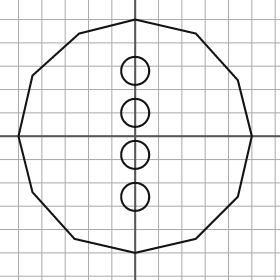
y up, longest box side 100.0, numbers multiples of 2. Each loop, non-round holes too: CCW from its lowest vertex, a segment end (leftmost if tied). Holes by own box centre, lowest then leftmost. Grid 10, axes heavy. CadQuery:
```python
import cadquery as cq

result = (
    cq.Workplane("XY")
    .moveTo(0.0, -50.0)
    .lineTo(26.0, -44.0)
    .lineTo(44.0, -26.0)
    .lineTo(50.0, 0.0)
    .lineTo(44.0, 24.0)
    .lineTo(26.0, 44.0)
    .lineTo(0.0, 50.0)
    .lineTo(-24.0, 44.0)
    .lineTo(-44.0, 26.0)
    .lineTo(-50.0, 0.0)
    .lineTo(-44.0, -24.0)
    .lineTo(-26.0, -44.0)
    .close()
    .moveTo(0.0, -26.0)
    .circle(6.0)
    .moveTo(0.0, -8.0)
    .circle(6.0)
    .moveTo(0.0, 10.0)
    .circle(6.0)
    .moveTo(0.0, 28.0)
    .circle(6.0)
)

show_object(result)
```